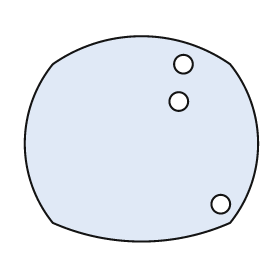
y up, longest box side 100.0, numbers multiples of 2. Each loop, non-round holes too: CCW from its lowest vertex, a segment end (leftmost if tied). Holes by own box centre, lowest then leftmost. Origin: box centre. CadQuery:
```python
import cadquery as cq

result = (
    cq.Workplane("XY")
    .moveTo(-38.0, -36.0)
    .threePointArc((0.0, -44.0), (38.0, -36.0))
    .threePointArc((50.0, -2.0), (38.0, 32.0))
    .threePointArc((0.0, 44.0), (-38.0, 32.0))
    .threePointArc((-50.0, -2.0), (-38.0, -36.0))
    .close()
    .moveTo(34.0, -28.0)
    .circle(4.0)
    .moveTo(16.0, 16.0)
    .circle(4.0)
    .moveTo(18.0, 32.0)
    .circle(4.0)
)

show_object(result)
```